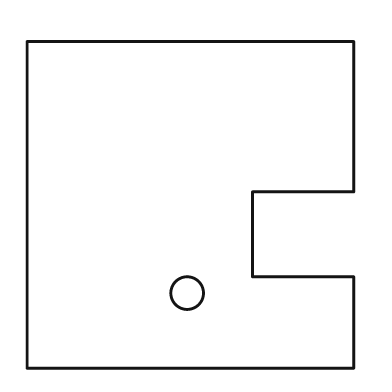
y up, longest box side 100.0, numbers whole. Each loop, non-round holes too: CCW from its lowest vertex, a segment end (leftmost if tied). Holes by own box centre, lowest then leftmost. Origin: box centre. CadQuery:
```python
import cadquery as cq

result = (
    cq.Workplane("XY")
    .moveTo(-50.0, -50.0)
    .lineTo(50.0, -50.0)
    .lineTo(50.0, -22.0)
    .lineTo(19.0, -22.0)
    .lineTo(19.0, 4.0)
    .lineTo(50.0, 4.0)
    .lineTo(50.0, 50.0)
    .lineTo(-50.0, 50.0)
    .close()
    .moveTo(-1.0, -27.0)
    .circle(5.0)
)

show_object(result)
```